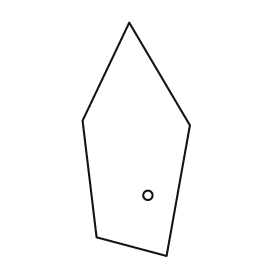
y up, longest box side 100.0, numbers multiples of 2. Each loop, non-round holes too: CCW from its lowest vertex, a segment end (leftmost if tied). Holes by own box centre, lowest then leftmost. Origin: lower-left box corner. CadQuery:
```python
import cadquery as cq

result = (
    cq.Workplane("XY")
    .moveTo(36.0, 0.0)
    .lineTo(46.0, 56.0)
    .lineTo(20.0, 100.0)
    .lineTo(0.0, 58.0)
    .lineTo(6.0, 8.0)
    .close()
    .moveTo(28.0, 26.0)
    .circle(2.0)
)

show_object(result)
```